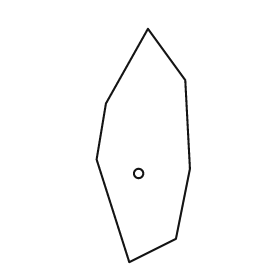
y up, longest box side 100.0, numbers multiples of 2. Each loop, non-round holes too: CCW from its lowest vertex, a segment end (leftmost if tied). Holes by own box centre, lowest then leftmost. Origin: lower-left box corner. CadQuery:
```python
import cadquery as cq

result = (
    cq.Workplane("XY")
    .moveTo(14.0, 0.0)
    .lineTo(34.0, 10.0)
    .lineTo(40.0, 40.0)
    .lineTo(38.0, 78.0)
    .lineTo(22.0, 100.0)
    .lineTo(4.0, 68.0)
    .lineTo(0.0, 44.0)
    .close()
    .moveTo(18.0, 38.0)
    .circle(2.0)
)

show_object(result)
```